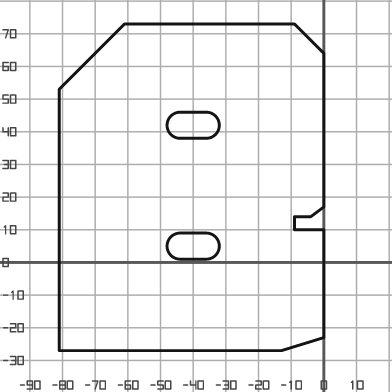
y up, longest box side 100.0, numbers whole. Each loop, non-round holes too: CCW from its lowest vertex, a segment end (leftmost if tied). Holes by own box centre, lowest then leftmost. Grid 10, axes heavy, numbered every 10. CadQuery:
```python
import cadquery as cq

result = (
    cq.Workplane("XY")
    .moveTo(-81.0, -27.0)
    .lineTo(-13.0, -27.0)
    .lineTo(0.0, -23.0)
    .lineTo(0.0, 10.0)
    .lineTo(-9.0, 10.0)
    .lineTo(-9.0, 14.0)
    .lineTo(-4.0, 14.0)
    .lineTo(0.0, 17.0)
    .lineTo(0.0, 64.0)
    .lineTo(-9.0, 73.0)
    .lineTo(-61.0, 73.0)
    .lineTo(-81.0, 53.0)
    .close()
    .moveTo(-44.0, 1.0)
    .lineTo(-36.0, 1.0)
    .threePointArc((-32.0, 5.0), (-36.0, 9.0))
    .lineTo(-44.0, 9.0)
    .threePointArc((-48.0, 5.0), (-44.0, 1.0))
    .close()
    .moveTo(-44.0, 38.0)
    .lineTo(-36.0, 38.0)
    .threePointArc((-32.0, 42.0), (-36.0, 46.0))
    .lineTo(-44.0, 46.0)
    .threePointArc((-48.0, 42.0), (-44.0, 38.0))
    .close()
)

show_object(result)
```